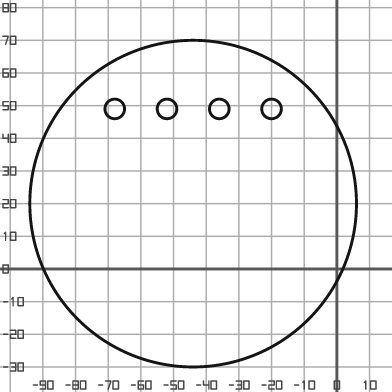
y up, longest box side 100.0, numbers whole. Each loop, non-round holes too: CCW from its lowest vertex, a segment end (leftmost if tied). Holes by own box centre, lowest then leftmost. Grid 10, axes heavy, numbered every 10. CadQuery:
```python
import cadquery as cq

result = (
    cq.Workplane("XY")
    .moveTo(-44.0, 20.0)
    .circle(50.0)
    .moveTo(-68.0, 49.0)
    .circle(3.0)
    .moveTo(-52.0, 49.0)
    .circle(3.0)
    .moveTo(-36.0, 49.0)
    .circle(3.0)
    .moveTo(-20.0, 49.0)
    .circle(3.0)
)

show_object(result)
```